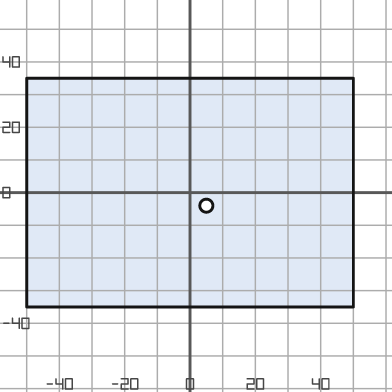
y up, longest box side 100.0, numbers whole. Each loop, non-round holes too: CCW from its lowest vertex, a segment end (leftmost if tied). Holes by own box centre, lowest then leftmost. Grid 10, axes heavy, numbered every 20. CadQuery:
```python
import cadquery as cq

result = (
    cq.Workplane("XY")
    .moveTo(-50.0, -35.0)
    .lineTo(50.0, -35.0)
    .lineTo(50.0, 35.0)
    .lineTo(-50.0, 35.0)
    .close()
    .moveTo(5.0, -4.0)
    .circle(2.0)
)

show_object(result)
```